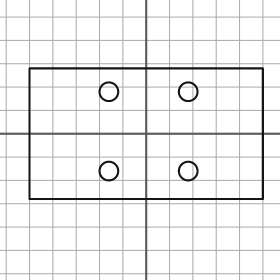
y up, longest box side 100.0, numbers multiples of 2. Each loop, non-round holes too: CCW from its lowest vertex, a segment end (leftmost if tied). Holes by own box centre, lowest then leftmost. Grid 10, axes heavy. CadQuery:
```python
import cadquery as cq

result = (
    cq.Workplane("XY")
    .moveTo(-50.0, -28.0)
    .lineTo(50.0, -28.0)
    .lineTo(50.0, 28.0)
    .lineTo(-50.0, 28.0)
    .close()
    .moveTo(-16.0, -16.0)
    .circle(4.0)
    .moveTo(18.0, -16.0)
    .circle(4.0)
    .moveTo(-16.0, 18.0)
    .circle(4.0)
    .moveTo(18.0, 18.0)
    .circle(4.0)
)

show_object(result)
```